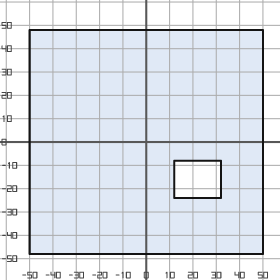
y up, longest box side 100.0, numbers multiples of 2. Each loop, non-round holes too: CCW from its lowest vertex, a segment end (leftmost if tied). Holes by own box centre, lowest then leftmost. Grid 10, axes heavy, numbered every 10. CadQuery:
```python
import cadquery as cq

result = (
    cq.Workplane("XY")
    .moveTo(-50.0, -48.0)
    .lineTo(50.0, -48.0)
    .lineTo(50.0, 48.0)
    .lineTo(-50.0, 48.0)
    .close()
    .moveTo(12.0, -24.0)
    .lineTo(32.0, -24.0)
    .lineTo(32.0, -8.0)
    .lineTo(12.0, -8.0)
    .close()
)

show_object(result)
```